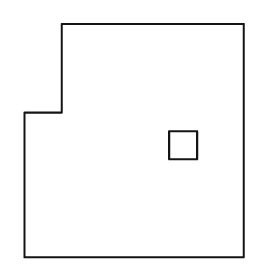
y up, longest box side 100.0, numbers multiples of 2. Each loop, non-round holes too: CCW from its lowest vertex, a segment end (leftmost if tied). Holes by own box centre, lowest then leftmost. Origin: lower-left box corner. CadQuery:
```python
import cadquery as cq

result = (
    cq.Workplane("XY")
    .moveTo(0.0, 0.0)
    .lineTo(94.0, 0.0)
    .lineTo(94.0, 100.0)
    .lineTo(16.0, 100.0)
    .lineTo(16.0, 62.0)
    .lineTo(0.0, 62.0)
    .close()
    .moveTo(62.0, 42.0)
    .lineTo(74.0, 42.0)
    .lineTo(74.0, 54.0)
    .lineTo(62.0, 54.0)
    .close()
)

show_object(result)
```